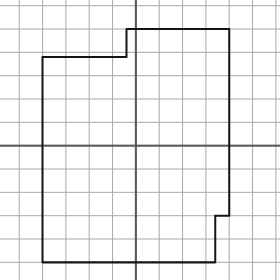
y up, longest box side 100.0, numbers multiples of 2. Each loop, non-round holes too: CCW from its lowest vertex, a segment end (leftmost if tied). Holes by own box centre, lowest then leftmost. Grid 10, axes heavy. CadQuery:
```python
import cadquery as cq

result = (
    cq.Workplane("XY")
    .moveTo(-40.0, -50.0)
    .lineTo(34.0, -50.0)
    .lineTo(34.0, -30.0)
    .lineTo(40.0, -30.0)
    .lineTo(40.0, 50.0)
    .lineTo(-4.0, 50.0)
    .lineTo(-4.0, 38.0)
    .lineTo(-40.0, 38.0)
    .close()
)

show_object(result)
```